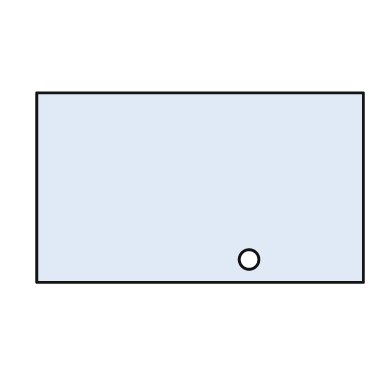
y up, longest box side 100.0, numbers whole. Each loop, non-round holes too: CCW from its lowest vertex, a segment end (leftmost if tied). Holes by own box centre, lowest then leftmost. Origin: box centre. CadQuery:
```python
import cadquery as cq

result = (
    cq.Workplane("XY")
    .moveTo(-50.0, -29.0)
    .lineTo(50.0, -29.0)
    .lineTo(50.0, 29.0)
    .lineTo(-50.0, 29.0)
    .close()
    .moveTo(15.0, -22.0)
    .circle(3.0)
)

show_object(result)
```